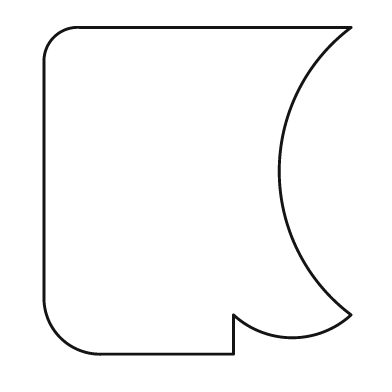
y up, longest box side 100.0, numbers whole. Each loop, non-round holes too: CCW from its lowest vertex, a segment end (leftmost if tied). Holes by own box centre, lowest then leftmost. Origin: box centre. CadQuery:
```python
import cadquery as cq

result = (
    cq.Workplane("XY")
    .moveTo(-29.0, -50.0)
    .lineTo(11.0, -50.0)
    .lineTo(11.0, -38.0)
    .threePointArc((29.0, -45.0), (47.0, -38.0))
    .threePointArc((25.0, 6.0), (47.0, 50.0))
    .lineTo(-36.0, 50.0)
    .threePointArc((-44.0, 47.0), (-47.0, 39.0))
    .lineTo(-47.0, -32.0)
    .threePointArc((-42.0, -45.0), (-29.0, -50.0))
    .close()
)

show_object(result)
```